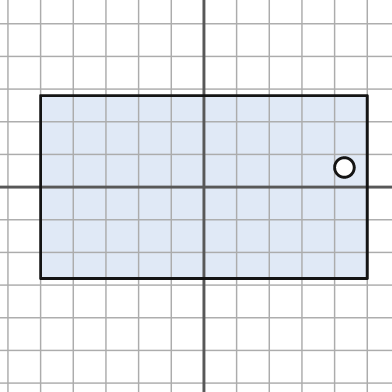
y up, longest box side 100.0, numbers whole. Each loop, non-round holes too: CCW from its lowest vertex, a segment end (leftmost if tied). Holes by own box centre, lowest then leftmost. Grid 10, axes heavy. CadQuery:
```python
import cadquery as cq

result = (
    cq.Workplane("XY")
    .moveTo(-50.0, -28.0)
    .lineTo(50.0, -28.0)
    .lineTo(50.0, 28.0)
    .lineTo(-50.0, 28.0)
    .close()
    .moveTo(43.0, 6.0)
    .circle(3.0)
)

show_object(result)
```